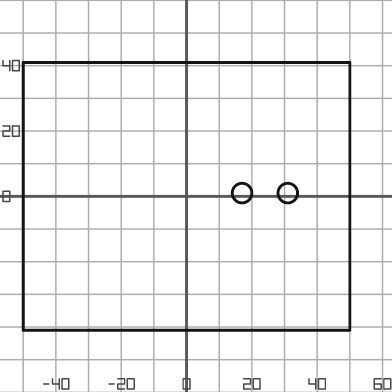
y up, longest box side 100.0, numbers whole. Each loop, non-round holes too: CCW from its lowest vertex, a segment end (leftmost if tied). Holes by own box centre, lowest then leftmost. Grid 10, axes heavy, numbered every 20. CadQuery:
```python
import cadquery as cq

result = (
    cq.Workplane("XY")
    .moveTo(-50.0, -41.0)
    .lineTo(50.0, -41.0)
    .lineTo(50.0, 41.0)
    .lineTo(-50.0, 41.0)
    .close()
    .moveTo(17.0, 1.0)
    .circle(3.0)
    .moveTo(31.0, 1.0)
    .circle(3.0)
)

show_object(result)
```